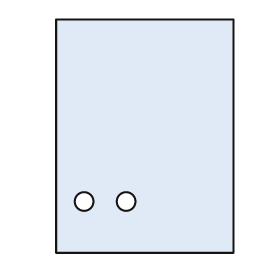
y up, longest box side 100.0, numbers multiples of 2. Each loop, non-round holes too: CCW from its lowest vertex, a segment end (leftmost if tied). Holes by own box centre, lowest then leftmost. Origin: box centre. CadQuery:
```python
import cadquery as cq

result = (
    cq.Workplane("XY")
    .moveTo(-38.0, -50.0)
    .lineTo(38.0, -50.0)
    .lineTo(38.0, 50.0)
    .lineTo(-38.0, 50.0)
    .close()
    .moveTo(-26.0, -28.0)
    .circle(4.0)
    .moveTo(-8.0, -28.0)
    .circle(4.0)
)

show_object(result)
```